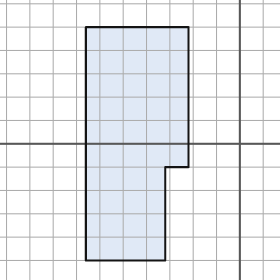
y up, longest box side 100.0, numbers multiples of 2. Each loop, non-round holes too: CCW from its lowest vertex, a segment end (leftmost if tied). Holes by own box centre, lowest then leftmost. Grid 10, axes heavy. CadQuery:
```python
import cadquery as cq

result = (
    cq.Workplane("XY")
    .moveTo(-66.0, -50.0)
    .lineTo(-32.0, -50.0)
    .lineTo(-32.0, -10.0)
    .lineTo(-22.0, -10.0)
    .lineTo(-22.0, 50.0)
    .lineTo(-66.0, 50.0)
    .close()
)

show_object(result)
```